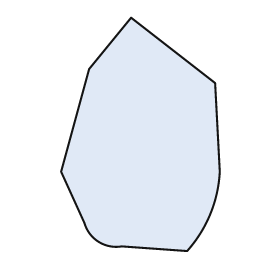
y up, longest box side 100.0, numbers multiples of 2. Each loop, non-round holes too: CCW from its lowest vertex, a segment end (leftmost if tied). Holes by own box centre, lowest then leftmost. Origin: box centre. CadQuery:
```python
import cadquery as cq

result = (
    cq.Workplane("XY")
    .moveTo(20.0, -50.0)
    .threePointArc((30.0, -34.0), (34.0, -16.0))
    .lineTo(32.0, 22.0)
    .lineTo(-4.0, 50.0)
    .lineTo(-22.0, 28.0)
    .lineTo(-34.0, -16.0)
    .lineTo(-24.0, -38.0)
    .threePointArc((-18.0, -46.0), (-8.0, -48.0))
    .close()
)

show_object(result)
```